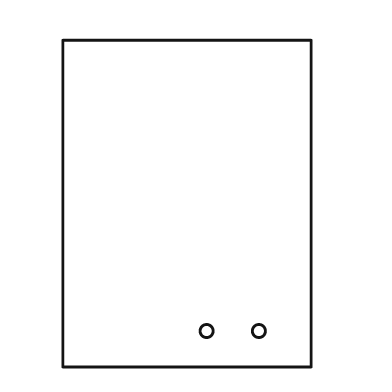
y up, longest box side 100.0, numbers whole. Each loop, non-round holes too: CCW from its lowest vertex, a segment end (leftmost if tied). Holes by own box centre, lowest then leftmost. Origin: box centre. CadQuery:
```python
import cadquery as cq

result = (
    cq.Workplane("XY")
    .moveTo(-38.0, -50.0)
    .lineTo(38.0, -50.0)
    .lineTo(38.0, 50.0)
    .lineTo(-38.0, 50.0)
    .close()
    .moveTo(6.0, -39.0)
    .circle(2.0)
    .moveTo(22.0, -39.0)
    .circle(2.0)
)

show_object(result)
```